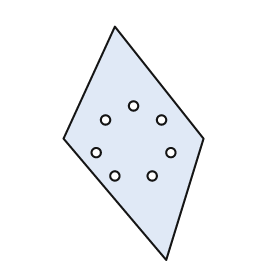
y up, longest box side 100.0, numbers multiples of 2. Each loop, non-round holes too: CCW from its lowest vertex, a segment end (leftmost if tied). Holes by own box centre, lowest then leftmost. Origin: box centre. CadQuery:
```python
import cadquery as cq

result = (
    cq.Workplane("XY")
    .moveTo(14.0, -50.0)
    .lineTo(30.0, 2.0)
    .lineTo(-8.0, 50.0)
    .lineTo(-30.0, 2.0)
    .close()
    .moveTo(-8.0, -14.0)
    .circle(2.0)
    .moveTo(8.0, -14.0)
    .circle(2.0)
    .moveTo(-16.0, -4.0)
    .circle(2.0)
    .moveTo(16.0, -4.0)
    .circle(2.0)
    .moveTo(-12.0, 10.0)
    .circle(2.0)
    .moveTo(12.0, 10.0)
    .circle(2.0)
    .moveTo(0.0, 16.0)
    .circle(2.0)
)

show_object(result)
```